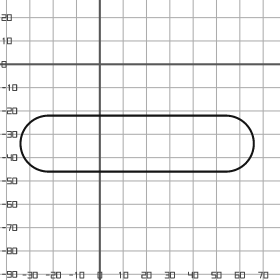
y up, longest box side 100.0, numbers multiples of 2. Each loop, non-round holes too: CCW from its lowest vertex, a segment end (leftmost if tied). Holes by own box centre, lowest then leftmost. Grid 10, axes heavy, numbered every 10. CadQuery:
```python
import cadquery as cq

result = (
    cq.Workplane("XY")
    .moveTo(-22.0, -46.0)
    .lineTo(54.0, -46.0)
    .threePointArc((66.0, -34.0), (54.0, -22.0))
    .lineTo(-22.0, -22.0)
    .threePointArc((-34.0, -34.0), (-22.0, -46.0))
    .close()
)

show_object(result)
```